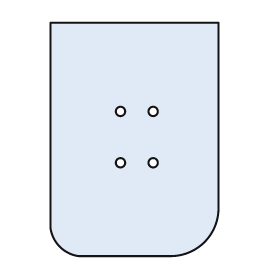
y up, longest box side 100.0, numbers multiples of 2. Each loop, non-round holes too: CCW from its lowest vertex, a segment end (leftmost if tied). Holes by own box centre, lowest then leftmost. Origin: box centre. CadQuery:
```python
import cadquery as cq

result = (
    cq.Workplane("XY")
    .moveTo(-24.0, -50.0)
    .lineTo(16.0, -50.0)
    .threePointArc((30.0, -44.0), (36.0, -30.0))
    .lineTo(36.0, 50.0)
    .lineTo(-36.0, 50.0)
    .lineTo(-36.0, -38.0)
    .threePointArc((-32.0, -46.0), (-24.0, -50.0))
    .close()
    .moveTo(-6.0, -10.0)
    .circle(2.0)
    .moveTo(8.0, -10.0)
    .circle(2.0)
    .moveTo(-6.0, 12.0)
    .circle(2.0)
    .moveTo(8.0, 12.0)
    .circle(2.0)
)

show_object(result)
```